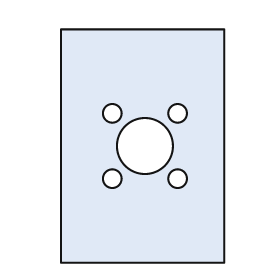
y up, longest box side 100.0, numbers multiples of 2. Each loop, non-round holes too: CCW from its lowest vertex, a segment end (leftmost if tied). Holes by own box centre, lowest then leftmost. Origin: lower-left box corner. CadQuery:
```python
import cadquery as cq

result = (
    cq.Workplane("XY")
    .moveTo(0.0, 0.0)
    .lineTo(70.0, 0.0)
    .lineTo(70.0, 100.0)
    .lineTo(0.0, 100.0)
    .close()
    .moveTo(22.0, 36.0)
    .circle(4.0)
    .moveTo(50.0, 36.0)
    .circle(4.0)
    .moveTo(36.0, 50.0)
    .circle(12.0)
    .moveTo(22.0, 64.0)
    .circle(4.0)
    .moveTo(50.0, 64.0)
    .circle(4.0)
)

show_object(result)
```